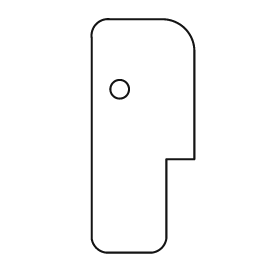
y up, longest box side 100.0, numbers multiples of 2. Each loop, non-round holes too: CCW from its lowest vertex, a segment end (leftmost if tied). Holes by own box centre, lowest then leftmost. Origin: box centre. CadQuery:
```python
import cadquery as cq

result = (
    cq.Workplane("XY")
    .moveTo(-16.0, -50.0)
    .lineTo(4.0, -50.0)
    .threePointArc((8.0, -48.0), (10.0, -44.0))
    .lineTo(10.0, -10.0)
    .lineTo(22.0, -10.0)
    .lineTo(22.0, 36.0)
    .threePointArc((18.0, 46.0), (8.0, 50.0))
    .lineTo(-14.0, 50.0)
    .threePointArc((-20.0, 48.0), (-22.0, 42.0))
    .lineTo(-22.0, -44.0)
    .threePointArc((-20.0, -48.0), (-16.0, -50.0))
    .close()
    .moveTo(-10.0, 20.0)
    .circle(4.0)
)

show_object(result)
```